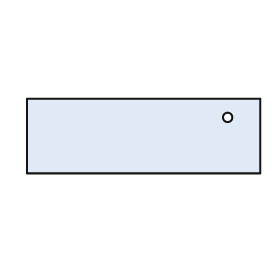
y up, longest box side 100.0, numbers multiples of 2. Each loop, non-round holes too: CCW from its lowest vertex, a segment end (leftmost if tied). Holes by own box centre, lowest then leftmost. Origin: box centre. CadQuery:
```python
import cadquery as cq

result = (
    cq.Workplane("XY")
    .moveTo(-50.0, -16.0)
    .lineTo(50.0, -16.0)
    .lineTo(50.0, 16.0)
    .lineTo(-50.0, 16.0)
    .close()
    .moveTo(36.0, 8.0)
    .circle(2.0)
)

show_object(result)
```